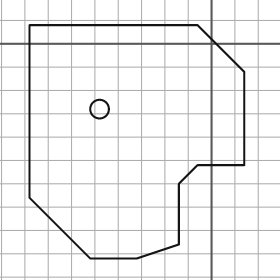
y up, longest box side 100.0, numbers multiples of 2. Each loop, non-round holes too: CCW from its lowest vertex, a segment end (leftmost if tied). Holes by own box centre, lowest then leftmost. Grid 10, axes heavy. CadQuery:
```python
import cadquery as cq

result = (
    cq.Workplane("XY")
    .moveTo(-52.0, -92.0)
    .lineTo(-32.0, -92.0)
    .lineTo(-14.0, -86.0)
    .lineTo(-14.0, -60.0)
    .lineTo(-6.0, -52.0)
    .lineTo(14.0, -52.0)
    .lineTo(14.0, -12.0)
    .lineTo(-6.0, 8.0)
    .lineTo(-78.0, 8.0)
    .lineTo(-78.0, -66.0)
    .close()
    .moveTo(-48.0, -28.0)
    .circle(4.0)
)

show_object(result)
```